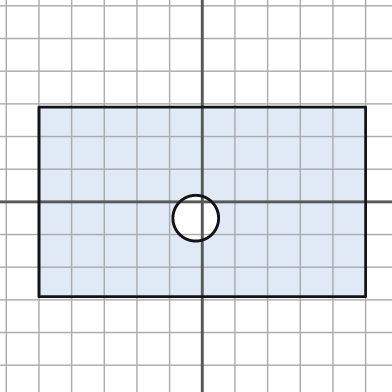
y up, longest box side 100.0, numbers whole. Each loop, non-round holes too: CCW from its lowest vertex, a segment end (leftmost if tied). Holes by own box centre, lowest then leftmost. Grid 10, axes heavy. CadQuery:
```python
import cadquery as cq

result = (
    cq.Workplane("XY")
    .moveTo(-50.0, -29.0)
    .lineTo(50.0, -29.0)
    .lineTo(50.0, 29.0)
    .lineTo(-50.0, 29.0)
    .close()
    .moveTo(-2.0, -5.0)
    .circle(7.0)
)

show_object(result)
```